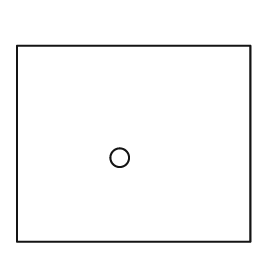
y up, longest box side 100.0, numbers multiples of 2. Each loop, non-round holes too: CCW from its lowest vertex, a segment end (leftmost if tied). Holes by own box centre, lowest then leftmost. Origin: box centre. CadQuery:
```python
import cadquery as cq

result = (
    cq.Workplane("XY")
    .moveTo(-50.0, -42.0)
    .lineTo(50.0, -42.0)
    .lineTo(50.0, 42.0)
    .lineTo(-50.0, 42.0)
    .close()
    .moveTo(-6.0, -6.0)
    .circle(4.0)
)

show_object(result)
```